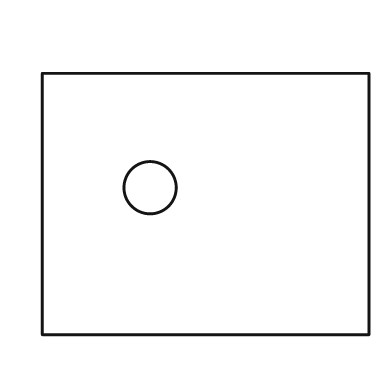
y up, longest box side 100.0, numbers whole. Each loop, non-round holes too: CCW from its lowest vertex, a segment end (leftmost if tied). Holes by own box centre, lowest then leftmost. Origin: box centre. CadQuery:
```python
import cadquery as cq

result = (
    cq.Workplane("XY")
    .moveTo(-50.0, -40.0)
    .lineTo(50.0, -40.0)
    .lineTo(50.0, 40.0)
    .lineTo(-50.0, 40.0)
    .close()
    .moveTo(-17.0, 5.0)
    .circle(8.0)
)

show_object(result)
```